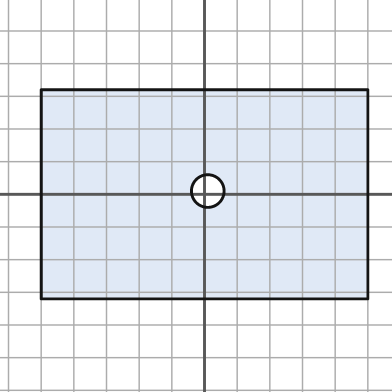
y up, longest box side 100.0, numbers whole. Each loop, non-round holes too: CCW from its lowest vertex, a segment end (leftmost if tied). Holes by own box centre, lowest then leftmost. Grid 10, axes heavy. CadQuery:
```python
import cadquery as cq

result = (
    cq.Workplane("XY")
    .moveTo(-50.0, -32.0)
    .lineTo(50.0, -32.0)
    .lineTo(50.0, 32.0)
    .lineTo(-50.0, 32.0)
    .close()
    .moveTo(1.0, 1.0)
    .circle(5.0)
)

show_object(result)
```